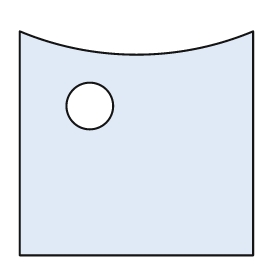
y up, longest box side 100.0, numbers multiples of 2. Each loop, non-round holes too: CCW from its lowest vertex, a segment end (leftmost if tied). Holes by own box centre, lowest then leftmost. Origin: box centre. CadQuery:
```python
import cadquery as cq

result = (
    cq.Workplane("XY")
    .moveTo(-50.0, -48.0)
    .lineTo(50.0, -48.0)
    .lineTo(50.0, 48.0)
    .threePointArc((0.0, 38.0), (-50.0, 48.0))
    .close()
    .moveTo(-20.0, 16.0)
    .circle(10.0)
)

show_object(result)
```